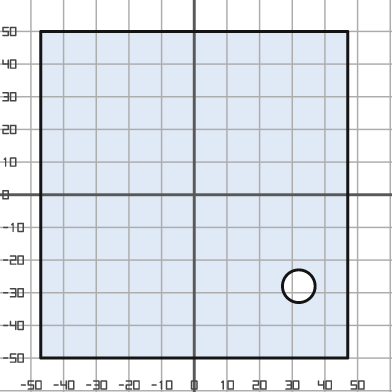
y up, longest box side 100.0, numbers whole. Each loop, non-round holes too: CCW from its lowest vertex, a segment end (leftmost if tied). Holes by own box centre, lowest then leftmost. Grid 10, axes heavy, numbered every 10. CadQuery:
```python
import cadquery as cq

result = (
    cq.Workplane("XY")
    .moveTo(-47.0, -50.0)
    .lineTo(47.0, -50.0)
    .lineTo(47.0, 50.0)
    .lineTo(-47.0, 50.0)
    .close()
    .moveTo(32.0, -28.0)
    .circle(5.0)
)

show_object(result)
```